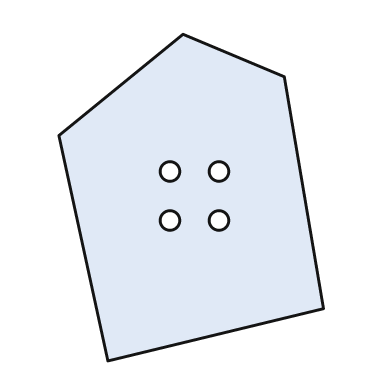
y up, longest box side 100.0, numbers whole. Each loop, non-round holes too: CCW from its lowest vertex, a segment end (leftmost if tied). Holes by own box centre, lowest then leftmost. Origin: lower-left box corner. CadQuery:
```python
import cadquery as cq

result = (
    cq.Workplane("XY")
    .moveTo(15.0, 0.0)
    .lineTo(81.0, 16.0)
    .lineTo(69.0, 87.0)
    .lineTo(38.0, 100.0)
    .lineTo(0.0, 69.0)
    .close()
    .moveTo(34.0, 43.0)
    .circle(3.0)
    .moveTo(49.0, 43.0)
    .circle(3.0)
    .moveTo(34.0, 58.0)
    .circle(3.0)
    .moveTo(49.0, 58.0)
    .circle(3.0)
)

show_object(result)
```